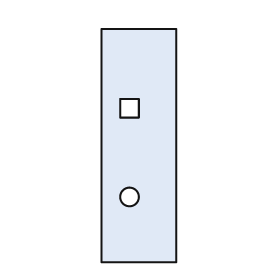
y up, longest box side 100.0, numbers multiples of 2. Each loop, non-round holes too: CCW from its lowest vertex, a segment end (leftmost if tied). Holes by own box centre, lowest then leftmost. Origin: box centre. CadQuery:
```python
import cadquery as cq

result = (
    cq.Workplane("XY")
    .moveTo(-16.0, -50.0)
    .lineTo(16.0, -50.0)
    .lineTo(16.0, 50.0)
    .lineTo(-16.0, 50.0)
    .close()
    .moveTo(-4.0, -22.0)
    .circle(4.0)
    .moveTo(-8.0, 12.0)
    .lineTo(0.0, 12.0)
    .lineTo(0.0, 20.0)
    .lineTo(-8.0, 20.0)
    .close()
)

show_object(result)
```